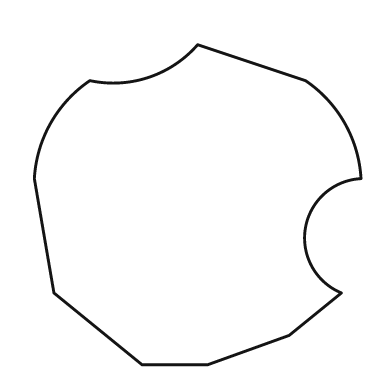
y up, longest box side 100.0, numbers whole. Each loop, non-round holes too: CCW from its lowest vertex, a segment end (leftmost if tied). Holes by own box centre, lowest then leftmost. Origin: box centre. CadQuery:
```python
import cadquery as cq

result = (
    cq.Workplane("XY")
    .moveTo(-17.0, -49.0)
    .lineTo(3.0, -49.0)
    .lineTo(28.0, -40.0)
    .lineTo(44.0, -27.0)
    .threePointArc((33.0, -7.0), (50.0, 8.0))
    .threePointArc((45.0, 25.0), (33.0, 38.0))
    .lineTo(0.0, 49.0)
    .threePointArc((-15.0, 39.0), (-33.0, 38.0))
    .threePointArc((-45.0, 25.0), (-50.0, 8.0))
    .lineTo(-44.0, -27.0)
    .close()
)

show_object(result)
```